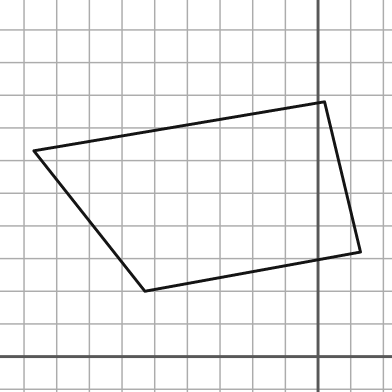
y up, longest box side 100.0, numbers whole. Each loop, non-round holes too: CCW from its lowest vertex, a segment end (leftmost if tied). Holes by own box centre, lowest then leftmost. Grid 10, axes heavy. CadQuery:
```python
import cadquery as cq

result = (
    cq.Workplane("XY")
    .moveTo(-53.0, 20.0)
    .lineTo(13.0, 32.0)
    .lineTo(2.0, 78.0)
    .lineTo(-87.0, 63.0)
    .close()
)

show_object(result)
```